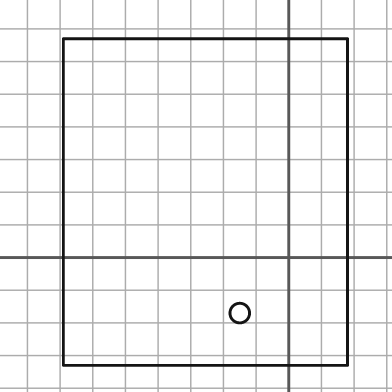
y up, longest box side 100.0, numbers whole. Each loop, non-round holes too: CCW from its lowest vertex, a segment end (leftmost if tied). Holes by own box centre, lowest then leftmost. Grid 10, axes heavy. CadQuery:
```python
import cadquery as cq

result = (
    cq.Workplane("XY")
    .moveTo(-69.0, -33.0)
    .lineTo(18.0, -33.0)
    .lineTo(18.0, 67.0)
    .lineTo(-69.0, 67.0)
    .close()
    .moveTo(-15.0, -17.0)
    .circle(3.0)
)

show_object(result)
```